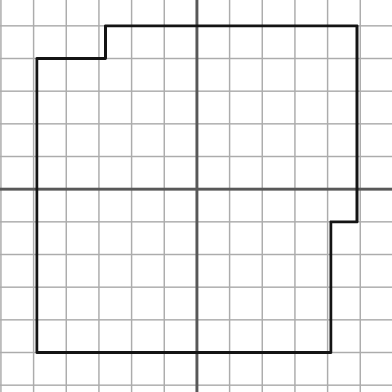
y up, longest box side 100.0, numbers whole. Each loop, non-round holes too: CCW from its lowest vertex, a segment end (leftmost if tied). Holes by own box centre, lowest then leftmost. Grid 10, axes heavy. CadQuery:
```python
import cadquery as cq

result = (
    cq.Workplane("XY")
    .moveTo(-49.0, -50.0)
    .lineTo(41.0, -50.0)
    .lineTo(41.0, -10.0)
    .lineTo(49.0, -10.0)
    .lineTo(49.0, 50.0)
    .lineTo(-28.0, 50.0)
    .lineTo(-28.0, 40.0)
    .lineTo(-49.0, 40.0)
    .close()
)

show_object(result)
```